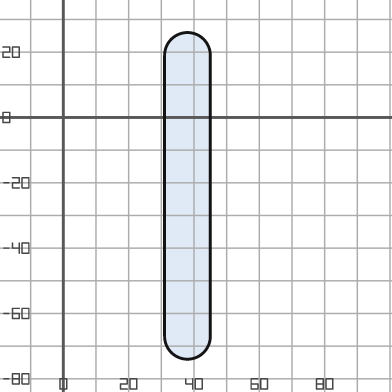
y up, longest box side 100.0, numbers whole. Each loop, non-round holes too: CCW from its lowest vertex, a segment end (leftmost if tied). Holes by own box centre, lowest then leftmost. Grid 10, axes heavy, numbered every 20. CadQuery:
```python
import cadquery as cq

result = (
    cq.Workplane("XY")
    .moveTo(31.0, -67.0)
    .threePointArc((38.0, -74.0), (45.0, -67.0))
    .lineTo(45.0, 19.0)
    .threePointArc((38.0, 26.0), (31.0, 19.0))
    .close()
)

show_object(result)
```